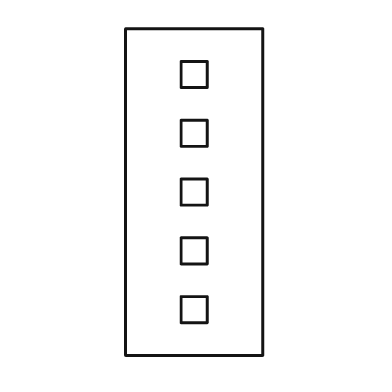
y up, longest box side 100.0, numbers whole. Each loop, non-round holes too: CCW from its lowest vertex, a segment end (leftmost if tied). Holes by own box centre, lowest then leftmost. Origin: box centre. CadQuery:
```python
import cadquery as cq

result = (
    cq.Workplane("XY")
    .moveTo(-21.0, -50.0)
    .lineTo(21.0, -50.0)
    .lineTo(21.0, 50.0)
    .lineTo(-21.0, 50.0)
    .close()
    .moveTo(-4.0, -40.0)
    .lineTo(4.0, -40.0)
    .lineTo(4.0, -32.0)
    .lineTo(-4.0, -32.0)
    .close()
    .moveTo(-4.0, -22.0)
    .lineTo(4.0, -22.0)
    .lineTo(4.0, -14.0)
    .lineTo(-4.0, -14.0)
    .close()
    .moveTo(-4.0, -4.0)
    .lineTo(4.0, -4.0)
    .lineTo(4.0, 4.0)
    .lineTo(-4.0, 4.0)
    .close()
    .moveTo(-4.0, 14.0)
    .lineTo(4.0, 14.0)
    .lineTo(4.0, 22.0)
    .lineTo(-4.0, 22.0)
    .close()
    .moveTo(-4.0, 32.0)
    .lineTo(4.0, 32.0)
    .lineTo(4.0, 40.0)
    .lineTo(-4.0, 40.0)
    .close()
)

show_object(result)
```